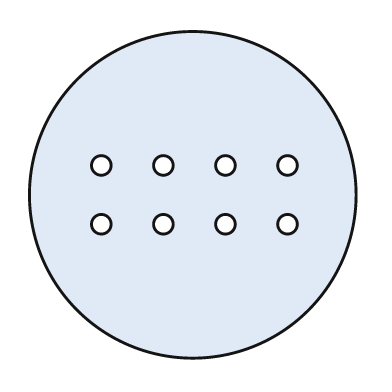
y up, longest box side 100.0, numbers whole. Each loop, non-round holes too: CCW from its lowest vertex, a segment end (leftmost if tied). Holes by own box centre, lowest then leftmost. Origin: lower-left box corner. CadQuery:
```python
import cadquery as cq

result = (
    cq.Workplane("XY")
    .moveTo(50.0, 50.0)
    .circle(50.0)
    .moveTo(22.0, 41.0)
    .circle(3.0)
    .moveTo(41.0, 41.0)
    .circle(3.0)
    .moveTo(60.0, 41.0)
    .circle(3.0)
    .moveTo(79.0, 41.0)
    .circle(3.0)
    .moveTo(22.0, 59.0)
    .circle(3.0)
    .moveTo(41.0, 59.0)
    .circle(3.0)
    .moveTo(60.0, 59.0)
    .circle(3.0)
    .moveTo(79.0, 59.0)
    .circle(3.0)
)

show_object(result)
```